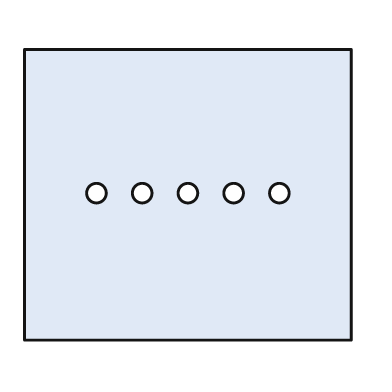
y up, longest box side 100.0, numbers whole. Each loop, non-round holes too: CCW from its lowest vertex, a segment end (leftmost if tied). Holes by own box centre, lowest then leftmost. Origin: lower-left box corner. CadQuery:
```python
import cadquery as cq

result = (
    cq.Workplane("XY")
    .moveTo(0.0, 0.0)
    .lineTo(100.0, 0.0)
    .lineTo(100.0, 89.0)
    .lineTo(0.0, 89.0)
    .close()
    .moveTo(22.0, 45.0)
    .circle(3.0)
    .moveTo(36.0, 45.0)
    .circle(3.0)
    .moveTo(50.0, 45.0)
    .circle(3.0)
    .moveTo(64.0, 45.0)
    .circle(3.0)
    .moveTo(78.0, 45.0)
    .circle(3.0)
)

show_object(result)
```